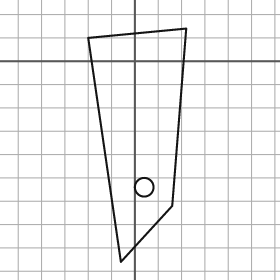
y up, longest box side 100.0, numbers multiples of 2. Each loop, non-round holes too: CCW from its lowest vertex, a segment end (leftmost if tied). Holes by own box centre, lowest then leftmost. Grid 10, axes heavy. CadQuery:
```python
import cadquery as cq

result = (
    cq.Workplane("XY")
    .moveTo(-6.0, -86.0)
    .lineTo(16.0, -62.0)
    .lineTo(22.0, 14.0)
    .lineTo(-20.0, 10.0)
    .close()
    .moveTo(4.0, -54.0)
    .circle(4.0)
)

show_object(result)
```